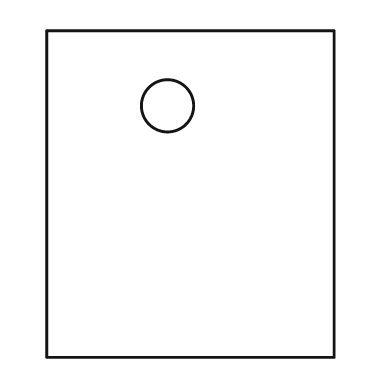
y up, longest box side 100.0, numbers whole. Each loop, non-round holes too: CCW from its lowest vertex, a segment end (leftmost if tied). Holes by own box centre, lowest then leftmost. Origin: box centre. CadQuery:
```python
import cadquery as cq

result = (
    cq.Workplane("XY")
    .moveTo(-44.0, -50.0)
    .lineTo(44.0, -50.0)
    .lineTo(44.0, 50.0)
    .lineTo(-44.0, 50.0)
    .close()
    .moveTo(-7.0, 27.0)
    .circle(8.0)
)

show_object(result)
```